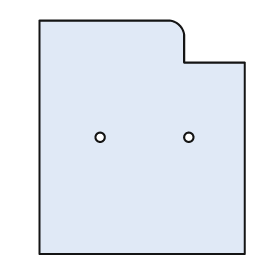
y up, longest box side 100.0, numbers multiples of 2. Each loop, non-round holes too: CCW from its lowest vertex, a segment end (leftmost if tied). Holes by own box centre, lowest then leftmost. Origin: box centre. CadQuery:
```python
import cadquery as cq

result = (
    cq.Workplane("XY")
    .moveTo(-44.0, -50.0)
    .lineTo(44.0, -50.0)
    .lineTo(44.0, 32.0)
    .lineTo(18.0, 32.0)
    .lineTo(18.0, 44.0)
    .threePointArc((16.0, 48.0), (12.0, 50.0))
    .lineTo(-44.0, 50.0)
    .close()
    .moveTo(-18.0, 0.0)
    .circle(2.0)
    .moveTo(20.0, 0.0)
    .circle(2.0)
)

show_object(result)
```